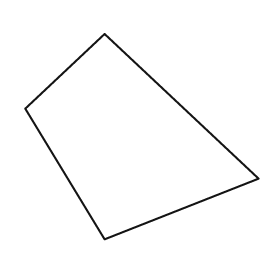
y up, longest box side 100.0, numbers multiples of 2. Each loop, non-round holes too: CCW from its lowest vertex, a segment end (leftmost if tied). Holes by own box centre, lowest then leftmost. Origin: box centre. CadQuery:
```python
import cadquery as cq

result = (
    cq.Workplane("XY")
    .moveTo(-16.0, -44.0)
    .lineTo(50.0, -18.0)
    .lineTo(-16.0, 44.0)
    .lineTo(-50.0, 12.0)
    .close()
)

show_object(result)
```